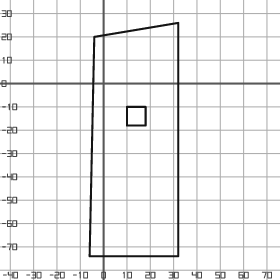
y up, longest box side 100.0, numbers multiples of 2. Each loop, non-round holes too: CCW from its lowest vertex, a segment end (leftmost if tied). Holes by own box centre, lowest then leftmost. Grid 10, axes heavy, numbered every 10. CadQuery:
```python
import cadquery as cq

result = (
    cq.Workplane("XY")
    .moveTo(-6.0, -74.0)
    .lineTo(32.0, -74.0)
    .lineTo(32.0, 26.0)
    .lineTo(-4.0, 20.0)
    .close()
    .moveTo(10.0, -18.0)
    .lineTo(18.0, -18.0)
    .lineTo(18.0, -10.0)
    .lineTo(10.0, -10.0)
    .close()
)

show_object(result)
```